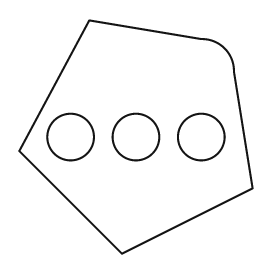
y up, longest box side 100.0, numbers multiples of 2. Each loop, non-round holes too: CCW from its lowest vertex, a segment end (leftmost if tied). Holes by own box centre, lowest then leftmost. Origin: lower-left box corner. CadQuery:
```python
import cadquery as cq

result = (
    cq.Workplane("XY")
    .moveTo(44.0, 0.0)
    .lineTo(100.0, 28.0)
    .lineTo(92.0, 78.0)
    .threePointArc((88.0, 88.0), (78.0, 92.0))
    .lineTo(30.0, 100.0)
    .lineTo(0.0, 44.0)
    .close()
    .moveTo(22.0, 50.0)
    .circle(10.0)
    .moveTo(50.0, 50.0)
    .circle(10.0)
    .moveTo(78.0, 50.0)
    .circle(10.0)
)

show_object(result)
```